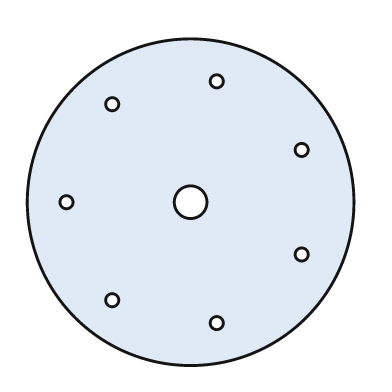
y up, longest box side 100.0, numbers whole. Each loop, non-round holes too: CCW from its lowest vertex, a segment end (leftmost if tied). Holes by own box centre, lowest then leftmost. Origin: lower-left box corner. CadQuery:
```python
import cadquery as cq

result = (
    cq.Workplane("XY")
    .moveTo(50.0, 50.0)
    .circle(50.0)
    .moveTo(58.0, 13.0)
    .circle(2.0)
    .moveTo(26.0, 20.0)
    .circle(2.0)
    .moveTo(84.0, 34.0)
    .circle(2.0)
    .moveTo(12.0, 50.0)
    .circle(2.0)
    .moveTo(50.0, 50.0)
    .circle(5.0)
    .moveTo(84.0, 66.0)
    .circle(2.0)
    .moveTo(26.0, 80.0)
    .circle(2.0)
    .moveTo(58.0, 87.0)
    .circle(2.0)
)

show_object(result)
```